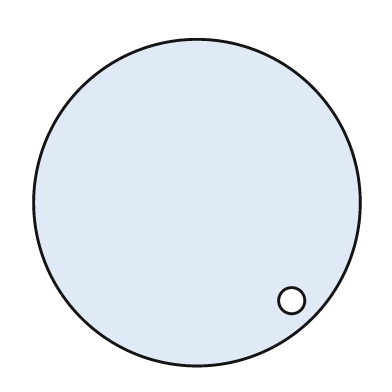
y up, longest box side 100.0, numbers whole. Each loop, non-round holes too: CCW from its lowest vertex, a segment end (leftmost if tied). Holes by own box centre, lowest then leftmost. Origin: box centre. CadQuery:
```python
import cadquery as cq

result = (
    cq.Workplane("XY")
    .moveTo(0.0, 0.0)
    .circle(50.0)
    .moveTo(29.0, -30.0)
    .circle(4.0)
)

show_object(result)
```